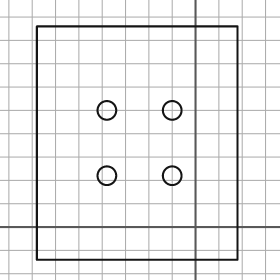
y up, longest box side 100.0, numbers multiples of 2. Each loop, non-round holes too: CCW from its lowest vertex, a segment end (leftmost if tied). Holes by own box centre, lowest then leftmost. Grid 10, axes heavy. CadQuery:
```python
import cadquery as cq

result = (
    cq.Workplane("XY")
    .moveTo(-68.0, -14.0)
    .lineTo(18.0, -14.0)
    .lineTo(18.0, 86.0)
    .lineTo(-68.0, 86.0)
    .close()
    .moveTo(-38.0, 22.0)
    .circle(4.0)
    .moveTo(-10.0, 22.0)
    .circle(4.0)
    .moveTo(-38.0, 50.0)
    .circle(4.0)
    .moveTo(-10.0, 50.0)
    .circle(4.0)
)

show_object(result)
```